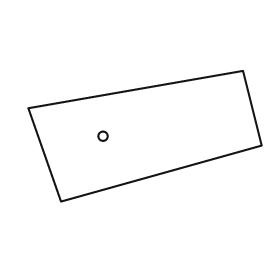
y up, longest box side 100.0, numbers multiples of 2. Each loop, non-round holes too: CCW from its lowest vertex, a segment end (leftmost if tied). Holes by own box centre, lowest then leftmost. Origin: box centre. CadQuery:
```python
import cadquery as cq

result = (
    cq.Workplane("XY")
    .moveTo(-36.0, -28.0)
    .lineTo(50.0, -4.0)
    .lineTo(42.0, 28.0)
    .lineTo(-50.0, 12.0)
    .close()
    .moveTo(-18.0, 0.0)
    .circle(2.0)
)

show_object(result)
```